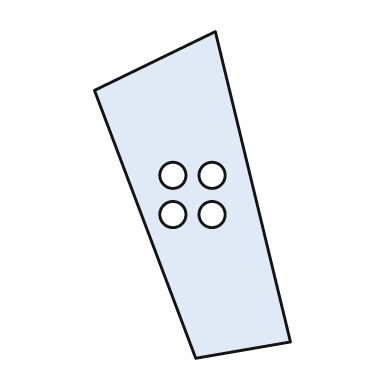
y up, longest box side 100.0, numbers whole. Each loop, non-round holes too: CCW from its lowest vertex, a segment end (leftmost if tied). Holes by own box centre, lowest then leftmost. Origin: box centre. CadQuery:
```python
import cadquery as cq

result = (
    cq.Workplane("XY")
    .moveTo(1.0, -50.0)
    .lineTo(30.0, -45.0)
    .lineTo(7.0, 50.0)
    .lineTo(-30.0, 32.0)
    .close()
    .moveTo(-6.0, -6.0)
    .circle(4.0)
    .moveTo(6.0, -6.0)
    .circle(4.0)
    .moveTo(-6.0, 6.0)
    .circle(4.0)
    .moveTo(6.0, 6.0)
    .circle(4.0)
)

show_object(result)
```